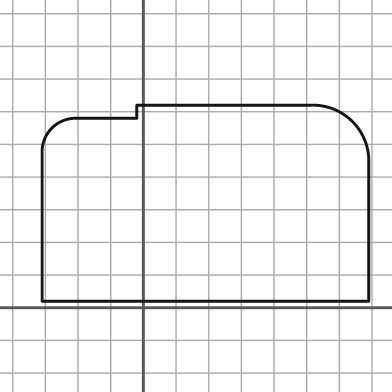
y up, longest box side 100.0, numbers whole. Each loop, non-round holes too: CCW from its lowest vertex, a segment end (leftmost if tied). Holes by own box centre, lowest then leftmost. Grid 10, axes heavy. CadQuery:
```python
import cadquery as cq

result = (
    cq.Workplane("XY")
    .moveTo(-31.0, 2.0)
    .lineTo(69.0, 2.0)
    .lineTo(69.0, 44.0)
    .threePointArc((64.0, 57.0), (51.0, 62.0))
    .lineTo(-2.0, 62.0)
    .lineTo(-2.0, 58.0)
    .lineTo(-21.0, 58.0)
    .threePointArc((-28.0, 55.0), (-31.0, 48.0))
    .close()
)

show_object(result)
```